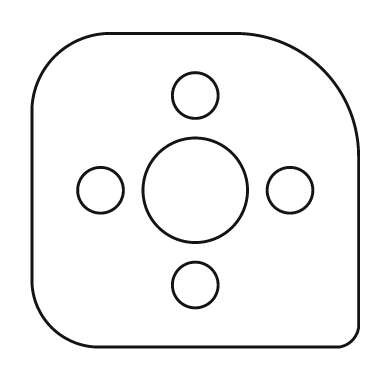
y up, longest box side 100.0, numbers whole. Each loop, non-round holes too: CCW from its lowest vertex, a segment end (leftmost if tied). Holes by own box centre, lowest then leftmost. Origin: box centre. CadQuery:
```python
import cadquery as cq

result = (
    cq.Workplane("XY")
    .moveTo(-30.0, -48.0)
    .lineTo(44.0, -48.0)
    .threePointArc((48.0, -46.0), (50.0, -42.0))
    .lineTo(50.0, 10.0)
    .threePointArc((39.0, 37.0), (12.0, 48.0))
    .lineTo(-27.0, 48.0)
    .threePointArc((-43.0, 41.0), (-50.0, 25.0))
    .lineTo(-50.0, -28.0)
    .threePointArc((-44.0, -42.0), (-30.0, -48.0))
    .close()
    .moveTo(0.0, -29.0)
    .circle(7.0)
    .moveTo(-29.0, 0.0)
    .circle(7.0)
    .moveTo(0.0, 0.0)
    .circle(16.0)
    .moveTo(29.0, 0.0)
    .circle(7.0)
    .moveTo(0.0, 29.0)
    .circle(7.0)
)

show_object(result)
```